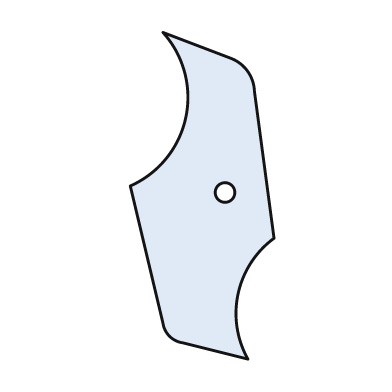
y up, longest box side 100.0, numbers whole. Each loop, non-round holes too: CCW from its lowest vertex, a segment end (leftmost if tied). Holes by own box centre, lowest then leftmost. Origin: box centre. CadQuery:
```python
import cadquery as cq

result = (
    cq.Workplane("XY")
    .moveTo(14.0, -50.0)
    .threePointArc((11.0, -30.0), (22.0, -13.0))
    .lineTo(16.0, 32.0)
    .threePointArc((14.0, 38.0), (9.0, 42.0))
    .lineTo(-12.0, 50.0)
    .threePointArc((-5.0, 24.0), (-22.0, 3.0))
    .lineTo(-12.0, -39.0)
    .threePointArc((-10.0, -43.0), (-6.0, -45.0))
    .close()
    .moveTo(7.0, 1.0)
    .circle(3.0)
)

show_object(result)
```